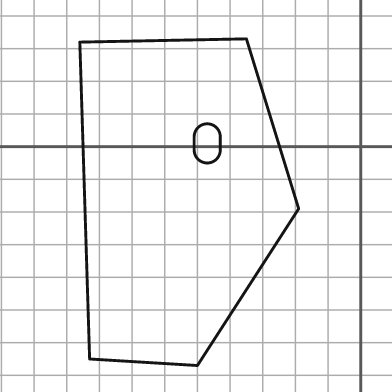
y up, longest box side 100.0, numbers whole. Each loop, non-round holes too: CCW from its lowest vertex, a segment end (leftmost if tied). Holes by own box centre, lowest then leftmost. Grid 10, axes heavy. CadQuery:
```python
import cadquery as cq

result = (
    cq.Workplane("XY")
    .moveTo(-50.0, -67.0)
    .lineTo(-19.0, -19.0)
    .lineTo(-35.0, 33.0)
    .lineTo(-86.0, 32.0)
    .lineTo(-83.0, -65.0)
    .close()
    .moveTo(-51.0, -1.0)
    .threePointArc((-47.0, -5.0), (-43.0, -1.0))
    .lineTo(-43.0, 3.0)
    .threePointArc((-47.0, 7.0), (-51.0, 3.0))
    .close()
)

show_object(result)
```